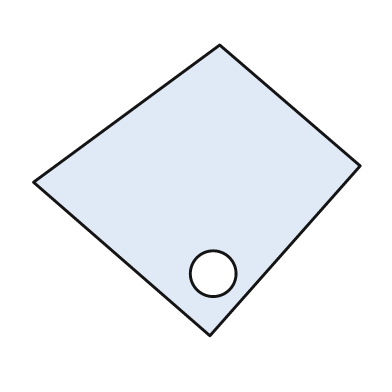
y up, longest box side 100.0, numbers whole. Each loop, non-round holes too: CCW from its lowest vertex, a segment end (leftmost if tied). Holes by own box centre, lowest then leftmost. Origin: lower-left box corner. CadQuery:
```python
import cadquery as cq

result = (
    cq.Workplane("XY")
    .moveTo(54.0, 0.0)
    .lineTo(100.0, 52.0)
    .lineTo(57.0, 89.0)
    .lineTo(0.0, 47.0)
    .close()
    .moveTo(55.0, 19.0)
    .circle(7.0)
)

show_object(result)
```